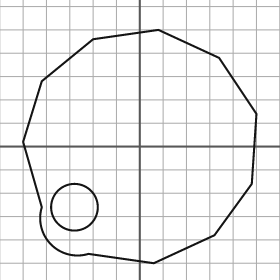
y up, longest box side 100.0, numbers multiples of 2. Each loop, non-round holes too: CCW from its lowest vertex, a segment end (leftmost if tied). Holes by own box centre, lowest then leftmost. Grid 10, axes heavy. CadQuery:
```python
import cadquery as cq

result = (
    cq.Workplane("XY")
    .moveTo(6.0, -50.0)
    .lineTo(32.0, -38.0)
    .lineTo(48.0, -16.0)
    .lineTo(50.0, 14.0)
    .lineTo(34.0, 38.0)
    .lineTo(8.0, 50.0)
    .lineTo(-20.0, 46.0)
    .lineTo(-42.0, 28.0)
    .lineTo(-50.0, 2.0)
    .lineTo(-42.0, -26.0)
    .threePointArc((-38.0, -42.0), (-22.0, -46.0))
    .close()
    .moveTo(-28.0, -26.0)
    .circle(10.0)
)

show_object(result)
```